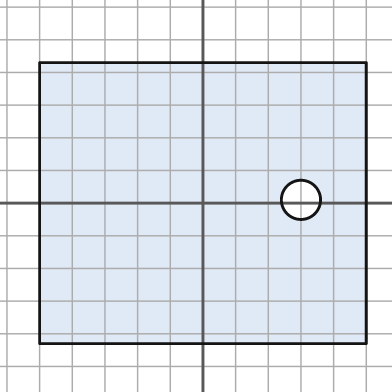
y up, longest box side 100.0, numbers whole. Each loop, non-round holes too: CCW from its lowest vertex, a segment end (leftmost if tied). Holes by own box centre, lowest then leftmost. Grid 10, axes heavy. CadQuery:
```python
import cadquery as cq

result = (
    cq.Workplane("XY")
    .moveTo(-50.0, -43.0)
    .lineTo(50.0, -43.0)
    .lineTo(50.0, 43.0)
    .lineTo(-50.0, 43.0)
    .close()
    .moveTo(30.0, 1.0)
    .circle(6.0)
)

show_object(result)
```